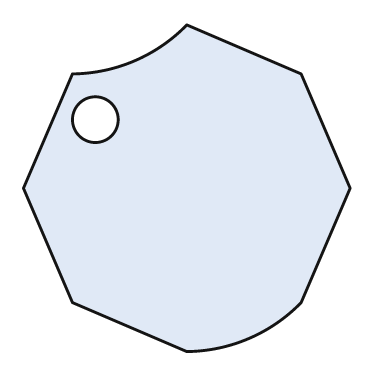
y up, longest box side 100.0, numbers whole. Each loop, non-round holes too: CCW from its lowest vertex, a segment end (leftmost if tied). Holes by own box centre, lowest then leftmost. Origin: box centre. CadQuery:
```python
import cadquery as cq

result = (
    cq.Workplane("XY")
    .moveTo(0.0, -50.0)
    .threePointArc((19.0, -46.0), (35.0, -35.0))
    .lineTo(50.0, 0.0)
    .lineTo(35.0, 35.0)
    .lineTo(0.0, 50.0)
    .threePointArc((-16.0, 39.0), (-35.0, 35.0))
    .lineTo(-50.0, 0.0)
    .lineTo(-35.0, -35.0)
    .close()
    .moveTo(-28.0, 21.0)
    .circle(7.0)
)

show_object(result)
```